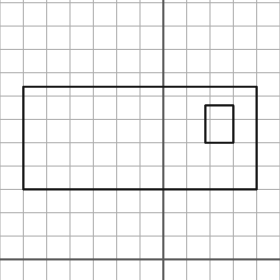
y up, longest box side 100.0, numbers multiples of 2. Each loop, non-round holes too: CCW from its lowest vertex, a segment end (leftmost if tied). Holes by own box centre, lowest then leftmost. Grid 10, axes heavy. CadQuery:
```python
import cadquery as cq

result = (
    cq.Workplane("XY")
    .moveTo(-60.0, 30.0)
    .lineTo(40.0, 30.0)
    .lineTo(40.0, 74.0)
    .lineTo(-60.0, 74.0)
    .close()
    .moveTo(18.0, 50.0)
    .lineTo(30.0, 50.0)
    .lineTo(30.0, 66.0)
    .lineTo(18.0, 66.0)
    .close()
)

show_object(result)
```